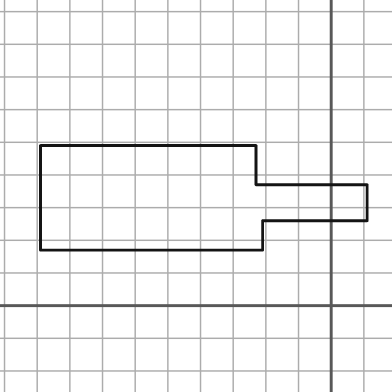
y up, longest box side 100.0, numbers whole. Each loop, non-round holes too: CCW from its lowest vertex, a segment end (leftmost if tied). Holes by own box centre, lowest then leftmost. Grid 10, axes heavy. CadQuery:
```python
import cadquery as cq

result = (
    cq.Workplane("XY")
    .moveTo(-89.0, 17.0)
    .lineTo(-21.0, 17.0)
    .lineTo(-21.0, 26.0)
    .lineTo(11.0, 26.0)
    .lineTo(11.0, 37.0)
    .lineTo(-23.0, 37.0)
    .lineTo(-23.0, 49.0)
    .lineTo(-89.0, 49.0)
    .close()
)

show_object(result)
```